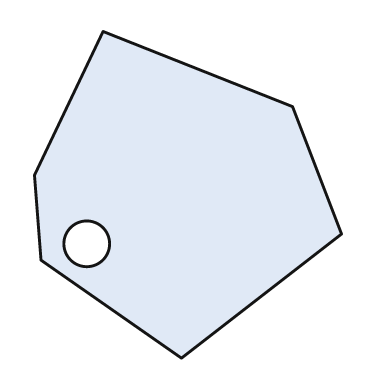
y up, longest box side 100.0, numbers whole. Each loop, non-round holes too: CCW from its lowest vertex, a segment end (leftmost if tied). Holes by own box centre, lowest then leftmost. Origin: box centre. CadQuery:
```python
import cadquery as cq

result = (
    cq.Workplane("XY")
    .moveTo(-2.0, -50.0)
    .lineTo(47.0, -12.0)
    .lineTo(32.0, 27.0)
    .lineTo(-26.0, 50.0)
    .lineTo(-47.0, 6.0)
    .lineTo(-45.0, -20.0)
    .close()
    .moveTo(-31.0, -15.0)
    .circle(7.0)
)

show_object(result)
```